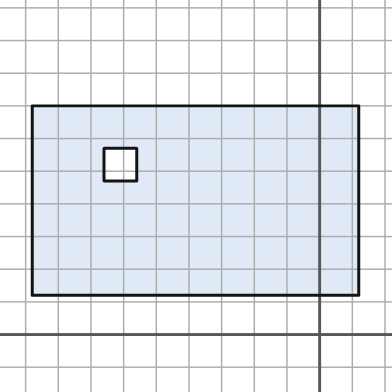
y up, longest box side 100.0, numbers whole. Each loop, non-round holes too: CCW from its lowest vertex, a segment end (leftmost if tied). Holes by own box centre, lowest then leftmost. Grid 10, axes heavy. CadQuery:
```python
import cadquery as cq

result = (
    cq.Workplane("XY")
    .moveTo(-88.0, 12.0)
    .lineTo(12.0, 12.0)
    .lineTo(12.0, 70.0)
    .lineTo(-88.0, 70.0)
    .close()
    .moveTo(-66.0, 47.0)
    .lineTo(-56.0, 47.0)
    .lineTo(-56.0, 57.0)
    .lineTo(-66.0, 57.0)
    .close()
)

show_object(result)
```